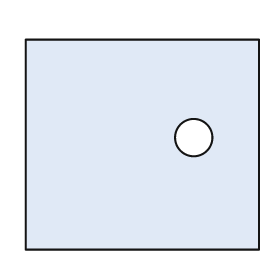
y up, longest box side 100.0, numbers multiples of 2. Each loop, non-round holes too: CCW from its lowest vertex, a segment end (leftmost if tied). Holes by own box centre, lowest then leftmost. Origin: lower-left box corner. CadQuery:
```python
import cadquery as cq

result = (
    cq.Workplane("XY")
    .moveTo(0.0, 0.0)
    .lineTo(100.0, 0.0)
    .lineTo(100.0, 90.0)
    .lineTo(0.0, 90.0)
    .close()
    .moveTo(72.0, 48.0)
    .circle(8.0)
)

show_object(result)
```